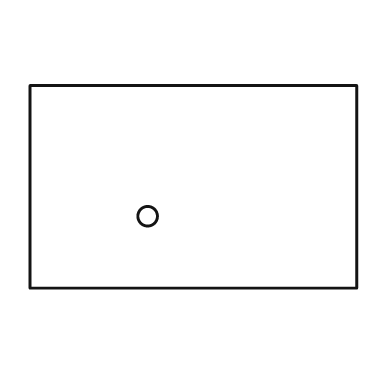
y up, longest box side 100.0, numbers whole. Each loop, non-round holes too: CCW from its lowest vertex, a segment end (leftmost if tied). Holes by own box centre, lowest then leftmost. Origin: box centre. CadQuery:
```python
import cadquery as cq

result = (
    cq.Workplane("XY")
    .moveTo(-50.0, -31.0)
    .lineTo(50.0, -31.0)
    .lineTo(50.0, 31.0)
    .lineTo(-50.0, 31.0)
    .close()
    .moveTo(-14.0, -9.0)
    .circle(3.0)
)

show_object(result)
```